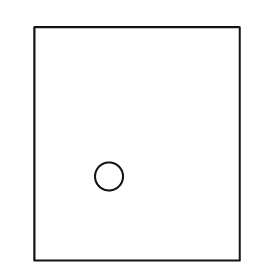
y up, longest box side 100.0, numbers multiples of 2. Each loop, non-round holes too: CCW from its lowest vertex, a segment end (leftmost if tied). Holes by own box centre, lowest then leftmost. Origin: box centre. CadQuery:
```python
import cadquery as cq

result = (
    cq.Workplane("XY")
    .moveTo(-44.0, -50.0)
    .lineTo(44.0, -50.0)
    .lineTo(44.0, 50.0)
    .lineTo(-44.0, 50.0)
    .close()
    .moveTo(-12.0, -14.0)
    .circle(6.0)
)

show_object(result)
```